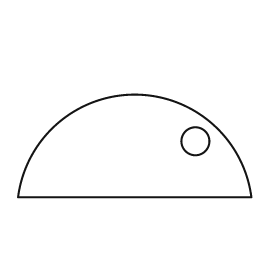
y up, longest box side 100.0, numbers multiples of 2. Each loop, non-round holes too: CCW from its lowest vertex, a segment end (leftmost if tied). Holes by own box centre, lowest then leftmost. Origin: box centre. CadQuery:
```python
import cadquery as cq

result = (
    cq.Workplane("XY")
    .moveTo(-50.0, -22.0)
    .lineTo(50.0, -22.0)
    .threePointArc((0.0, 22.0), (-50.0, -22.0))
    .close()
    .moveTo(26.0, 2.0)
    .circle(6.0)
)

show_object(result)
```